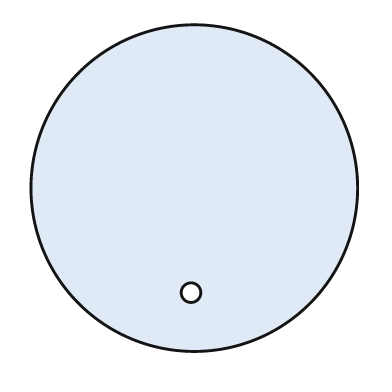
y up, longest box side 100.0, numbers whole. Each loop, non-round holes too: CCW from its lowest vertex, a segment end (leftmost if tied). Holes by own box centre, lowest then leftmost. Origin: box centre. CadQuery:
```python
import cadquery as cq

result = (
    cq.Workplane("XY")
    .moveTo(0.0, 0.0)
    .circle(50.0)
    .moveTo(-1.0, -32.0)
    .circle(3.0)
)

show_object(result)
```